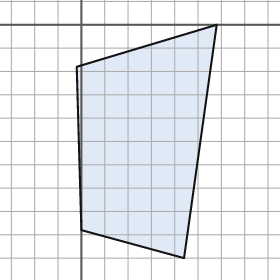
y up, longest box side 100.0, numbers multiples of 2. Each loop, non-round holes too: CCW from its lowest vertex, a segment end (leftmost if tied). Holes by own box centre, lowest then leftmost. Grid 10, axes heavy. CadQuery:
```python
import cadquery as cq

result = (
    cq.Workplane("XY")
    .moveTo(44.0, -100.0)
    .lineTo(58.0, 0.0)
    .lineTo(-2.0, -18.0)
    .lineTo(0.0, -88.0)
    .close()
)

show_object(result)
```